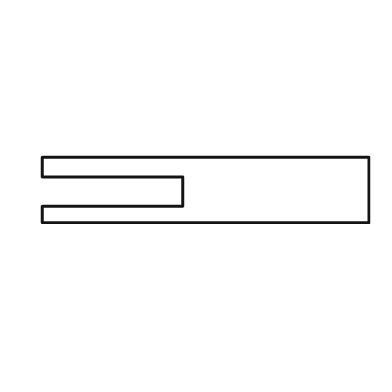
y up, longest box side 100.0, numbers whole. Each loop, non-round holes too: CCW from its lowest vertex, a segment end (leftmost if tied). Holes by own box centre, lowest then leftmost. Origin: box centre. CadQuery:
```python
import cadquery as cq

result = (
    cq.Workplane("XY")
    .moveTo(-50.0, -10.0)
    .lineTo(50.0, -10.0)
    .lineTo(50.0, 10.0)
    .lineTo(-50.0, 10.0)
    .lineTo(-50.0, 4.0)
    .lineTo(-7.0, 4.0)
    .lineTo(-7.0, -5.0)
    .lineTo(-50.0, -5.0)
    .close()
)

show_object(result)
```